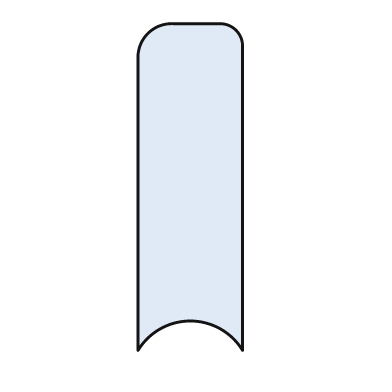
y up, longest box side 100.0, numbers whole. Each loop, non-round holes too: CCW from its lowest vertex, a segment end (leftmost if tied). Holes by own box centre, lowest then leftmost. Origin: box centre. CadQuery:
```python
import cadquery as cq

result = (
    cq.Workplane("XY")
    .moveTo(-16.0, -50.0)
    .threePointArc((0.0, -41.0), (16.0, -50.0))
    .lineTo(16.0, 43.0)
    .threePointArc((14.0, 48.0), (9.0, 50.0))
    .lineTo(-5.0, 50.0)
    .threePointArc((-13.0, 47.0), (-16.0, 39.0))
    .close()
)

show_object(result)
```